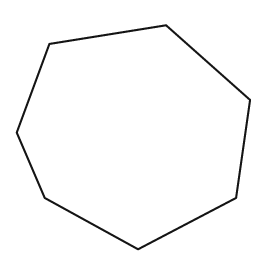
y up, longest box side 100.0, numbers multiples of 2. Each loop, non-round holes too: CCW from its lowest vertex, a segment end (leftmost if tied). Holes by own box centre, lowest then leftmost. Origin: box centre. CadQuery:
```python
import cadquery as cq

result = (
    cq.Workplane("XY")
    .moveTo(2.0, -48.0)
    .lineTo(44.0, -26.0)
    .lineTo(50.0, 16.0)
    .lineTo(14.0, 48.0)
    .lineTo(-36.0, 40.0)
    .lineTo(-50.0, 2.0)
    .lineTo(-38.0, -26.0)
    .close()
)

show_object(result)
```